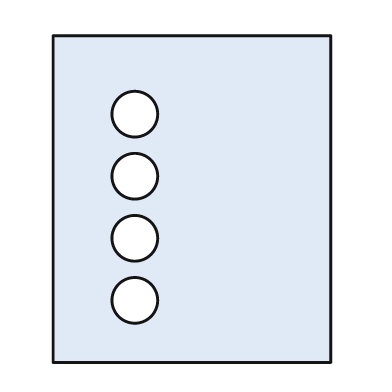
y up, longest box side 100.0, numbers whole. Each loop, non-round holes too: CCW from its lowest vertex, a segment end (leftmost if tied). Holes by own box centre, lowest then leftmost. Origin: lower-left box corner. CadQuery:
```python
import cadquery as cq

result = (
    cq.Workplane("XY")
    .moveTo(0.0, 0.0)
    .lineTo(85.0, 0.0)
    .lineTo(85.0, 100.0)
    .lineTo(0.0, 100.0)
    .close()
    .moveTo(25.0, 19.0)
    .circle(7.0)
    .moveTo(25.0, 38.0)
    .circle(7.0)
    .moveTo(25.0, 57.0)
    .circle(7.0)
    .moveTo(25.0, 76.0)
    .circle(7.0)
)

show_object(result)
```